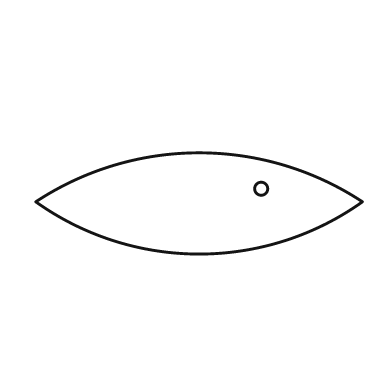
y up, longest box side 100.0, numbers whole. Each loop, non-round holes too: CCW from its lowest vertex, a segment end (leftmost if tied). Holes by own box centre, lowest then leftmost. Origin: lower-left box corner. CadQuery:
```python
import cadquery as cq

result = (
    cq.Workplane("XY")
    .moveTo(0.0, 16.0)
    .threePointArc((50.0, 0.0), (100.0, 16.0))
    .threePointArc((50.0, 31.0), (0.0, 16.0))
    .close()
    .moveTo(69.0, 20.0)
    .circle(2.0)
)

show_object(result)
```